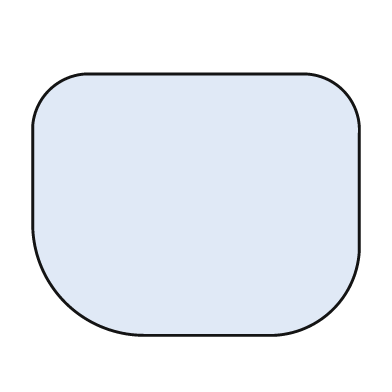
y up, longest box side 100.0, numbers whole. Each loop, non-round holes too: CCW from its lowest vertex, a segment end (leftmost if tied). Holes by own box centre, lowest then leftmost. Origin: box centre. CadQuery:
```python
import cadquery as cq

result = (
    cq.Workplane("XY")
    .moveTo(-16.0, -40.0)
    .lineTo(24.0, -40.0)
    .threePointArc((42.0, -32.0), (50.0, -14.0))
    .lineTo(50.0, 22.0)
    .threePointArc((45.0, 35.0), (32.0, 40.0))
    .lineTo(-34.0, 40.0)
    .threePointArc((-45.0, 35.0), (-50.0, 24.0))
    .lineTo(-50.0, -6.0)
    .threePointArc((-40.0, -30.0), (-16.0, -40.0))
    .close()
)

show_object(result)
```